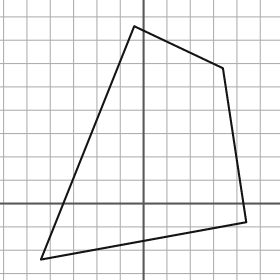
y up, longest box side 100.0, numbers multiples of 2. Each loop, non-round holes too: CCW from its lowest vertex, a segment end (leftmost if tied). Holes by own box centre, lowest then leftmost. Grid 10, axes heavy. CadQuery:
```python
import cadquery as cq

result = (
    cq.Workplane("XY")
    .moveTo(-44.0, -24.0)
    .lineTo(44.0, -8.0)
    .lineTo(34.0, 58.0)
    .lineTo(-4.0, 76.0)
    .close()
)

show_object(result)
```